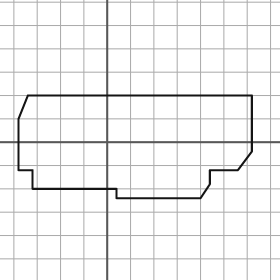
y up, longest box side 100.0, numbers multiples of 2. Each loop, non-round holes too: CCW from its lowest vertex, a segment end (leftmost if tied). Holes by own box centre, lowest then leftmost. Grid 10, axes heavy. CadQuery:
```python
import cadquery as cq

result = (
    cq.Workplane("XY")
    .moveTo(4.0, -24.0)
    .lineTo(40.0, -24.0)
    .lineTo(44.0, -18.0)
    .lineTo(44.0, -12.0)
    .lineTo(56.0, -12.0)
    .lineTo(62.0, -4.0)
    .lineTo(62.0, 20.0)
    .lineTo(-34.0, 20.0)
    .lineTo(-38.0, 10.0)
    .lineTo(-38.0, -12.0)
    .lineTo(-32.0, -12.0)
    .lineTo(-32.0, -20.0)
    .lineTo(4.0, -20.0)
    .close()
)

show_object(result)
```